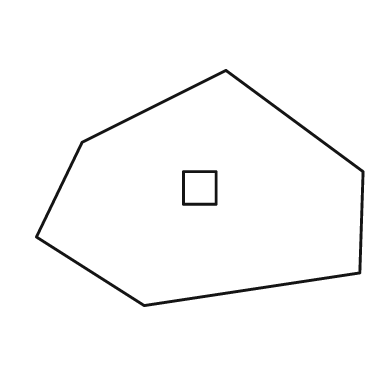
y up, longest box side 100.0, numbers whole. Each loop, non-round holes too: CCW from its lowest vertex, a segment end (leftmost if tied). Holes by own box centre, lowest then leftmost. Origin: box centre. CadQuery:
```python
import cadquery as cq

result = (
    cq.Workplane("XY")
    .moveTo(-17.0, -36.0)
    .lineTo(49.0, -26.0)
    .lineTo(50.0, 5.0)
    .lineTo(8.0, 36.0)
    .lineTo(-36.0, 14.0)
    .lineTo(-50.0, -15.0)
    .close()
    .moveTo(-5.0, -5.0)
    .lineTo(5.0, -5.0)
    .lineTo(5.0, 5.0)
    .lineTo(-5.0, 5.0)
    .close()
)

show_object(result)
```